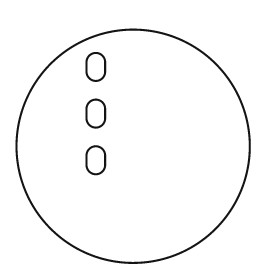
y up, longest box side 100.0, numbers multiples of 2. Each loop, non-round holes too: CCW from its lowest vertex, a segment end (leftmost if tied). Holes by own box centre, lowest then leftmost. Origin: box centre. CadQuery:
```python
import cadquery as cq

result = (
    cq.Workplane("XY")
    .moveTo(0.0, 0.0)
    .circle(50.0)
    .moveTo(-20.0, -8.0)
    .threePointArc((-16.0, -12.0), (-12.0, -8.0))
    .lineTo(-12.0, -4.0)
    .threePointArc((-16.0, 0.0), (-20.0, -4.0))
    .close()
    .moveTo(-20.0, 12.0)
    .threePointArc((-16.0, 8.0), (-12.0, 12.0))
    .lineTo(-12.0, 16.0)
    .threePointArc((-16.0, 20.0), (-20.0, 16.0))
    .close()
    .moveTo(-20.0, 32.0)
    .threePointArc((-16.0, 28.0), (-12.0, 32.0))
    .lineTo(-12.0, 36.0)
    .threePointArc((-16.0, 40.0), (-20.0, 36.0))
    .close()
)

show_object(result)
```